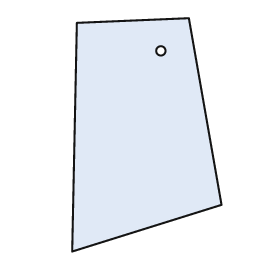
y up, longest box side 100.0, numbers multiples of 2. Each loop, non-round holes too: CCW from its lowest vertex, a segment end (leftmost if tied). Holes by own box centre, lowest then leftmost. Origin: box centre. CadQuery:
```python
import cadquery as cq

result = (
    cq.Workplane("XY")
    .moveTo(-32.0, -50.0)
    .lineTo(32.0, -30.0)
    .lineTo(18.0, 50.0)
    .lineTo(-30.0, 48.0)
    .close()
    .moveTo(6.0, 36.0)
    .circle(2.0)
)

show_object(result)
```